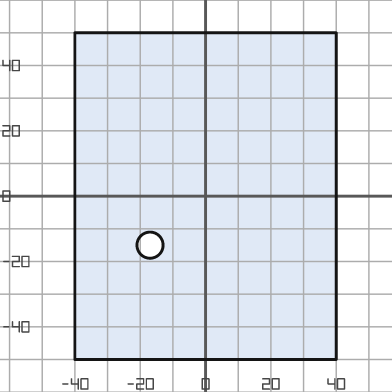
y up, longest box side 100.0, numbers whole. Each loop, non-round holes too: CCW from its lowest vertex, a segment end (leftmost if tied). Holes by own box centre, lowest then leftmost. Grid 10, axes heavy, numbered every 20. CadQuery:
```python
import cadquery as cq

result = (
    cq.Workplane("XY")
    .moveTo(-40.0, -50.0)
    .lineTo(40.0, -50.0)
    .lineTo(40.0, 50.0)
    .lineTo(-40.0, 50.0)
    .close()
    .moveTo(-17.0, -15.0)
    .circle(4.0)
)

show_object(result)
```